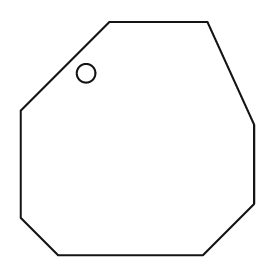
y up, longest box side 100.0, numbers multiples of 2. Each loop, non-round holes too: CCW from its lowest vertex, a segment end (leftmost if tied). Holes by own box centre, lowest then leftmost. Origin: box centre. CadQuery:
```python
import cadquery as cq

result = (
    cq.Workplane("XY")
    .moveTo(-34.0, -50.0)
    .lineTo(28.0, -50.0)
    .lineTo(50.0, -28.0)
    .lineTo(50.0, 6.0)
    .lineTo(30.0, 50.0)
    .lineTo(-12.0, 50.0)
    .lineTo(-50.0, 12.0)
    .lineTo(-50.0, -34.0)
    .close()
    .moveTo(-22.0, 28.0)
    .circle(4.0)
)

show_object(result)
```